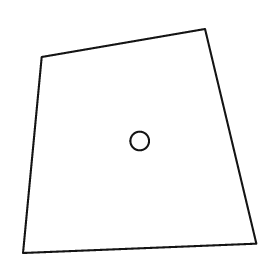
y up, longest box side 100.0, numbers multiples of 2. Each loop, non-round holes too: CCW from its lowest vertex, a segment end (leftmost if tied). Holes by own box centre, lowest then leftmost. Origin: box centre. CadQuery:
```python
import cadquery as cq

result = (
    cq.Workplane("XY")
    .moveTo(-50.0, -48.0)
    .lineTo(50.0, -44.0)
    .lineTo(28.0, 48.0)
    .lineTo(-42.0, 36.0)
    .close()
    .moveTo(0.0, 0.0)
    .circle(4.0)
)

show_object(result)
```